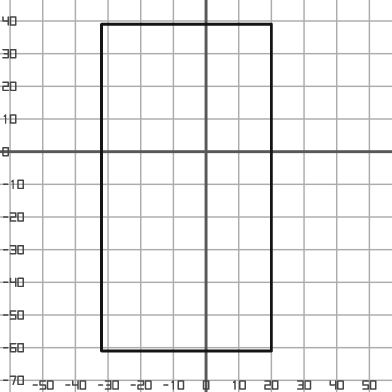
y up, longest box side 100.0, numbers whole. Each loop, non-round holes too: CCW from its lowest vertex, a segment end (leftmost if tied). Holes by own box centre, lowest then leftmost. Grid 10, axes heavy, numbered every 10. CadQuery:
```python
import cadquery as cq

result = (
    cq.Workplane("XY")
    .moveTo(-32.0, -61.0)
    .lineTo(20.0, -61.0)
    .lineTo(20.0, 39.0)
    .lineTo(-32.0, 39.0)
    .close()
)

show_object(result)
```